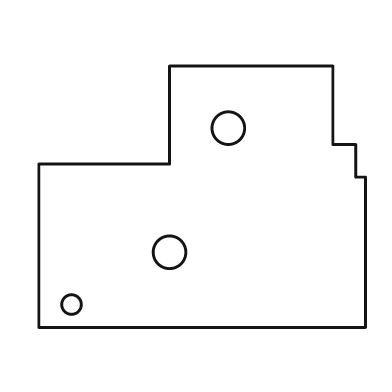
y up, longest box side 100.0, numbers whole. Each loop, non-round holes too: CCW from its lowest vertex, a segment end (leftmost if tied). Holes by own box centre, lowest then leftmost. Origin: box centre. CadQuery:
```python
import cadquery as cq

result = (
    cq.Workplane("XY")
    .moveTo(-50.0, -40.0)
    .lineTo(50.0, -40.0)
    .lineTo(50.0, 6.0)
    .lineTo(47.0, 6.0)
    .lineTo(47.0, 16.0)
    .lineTo(40.0, 16.0)
    .lineTo(40.0, 40.0)
    .lineTo(-10.0, 40.0)
    .lineTo(-10.0, 10.0)
    .lineTo(-50.0, 10.0)
    .close()
    .moveTo(-40.0, -33.0)
    .circle(3.0)
    .moveTo(-10.0, -17.0)
    .circle(5.0)
    .moveTo(8.0, 21.0)
    .circle(5.0)
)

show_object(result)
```